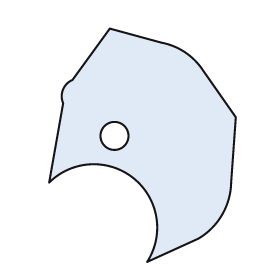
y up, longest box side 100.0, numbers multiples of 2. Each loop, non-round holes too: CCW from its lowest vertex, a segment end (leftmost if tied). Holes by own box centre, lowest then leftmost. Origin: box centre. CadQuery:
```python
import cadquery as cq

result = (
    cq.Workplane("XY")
    .moveTo(2.0, -50.0)
    .lineTo(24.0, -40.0)
    .threePointArc((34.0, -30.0), (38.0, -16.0))
    .lineTo(40.0, 12.0)
    .lineTo(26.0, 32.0)
    .threePointArc((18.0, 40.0), (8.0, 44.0))
    .lineTo(-14.0, 50.0)
    .lineTo(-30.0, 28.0)
    .threePointArc((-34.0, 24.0), (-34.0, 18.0))
    .lineTo(-40.0, -16.0)
    .threePointArc((-4.0, -14.0), (2.0, -50.0))
    .close()
    .moveTo(-12.0, 4.0)
    .circle(6.0)
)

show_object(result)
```